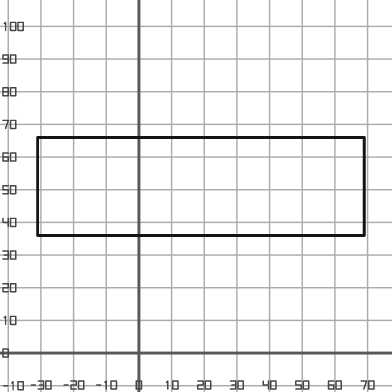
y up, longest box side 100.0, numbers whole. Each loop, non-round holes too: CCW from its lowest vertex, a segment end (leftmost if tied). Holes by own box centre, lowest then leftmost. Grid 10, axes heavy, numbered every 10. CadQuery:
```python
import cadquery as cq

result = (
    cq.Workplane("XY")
    .moveTo(-31.0, 36.0)
    .lineTo(69.0, 36.0)
    .lineTo(69.0, 66.0)
    .lineTo(-31.0, 66.0)
    .close()
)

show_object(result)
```